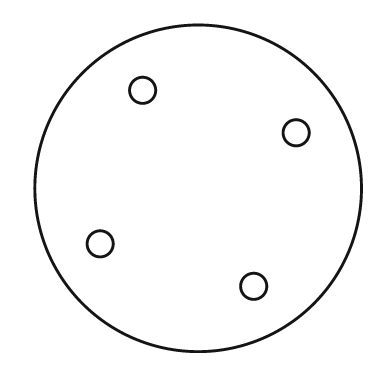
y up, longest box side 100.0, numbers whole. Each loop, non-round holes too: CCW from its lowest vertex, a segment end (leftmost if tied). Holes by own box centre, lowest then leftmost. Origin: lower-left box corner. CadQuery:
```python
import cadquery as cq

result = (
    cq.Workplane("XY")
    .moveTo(50.0, 50.0)
    .circle(50.0)
    .moveTo(67.0, 20.0)
    .circle(4.0)
    .moveTo(20.0, 33.0)
    .circle(4.0)
    .moveTo(80.0, 67.0)
    .circle(4.0)
    .moveTo(33.0, 80.0)
    .circle(4.0)
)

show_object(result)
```